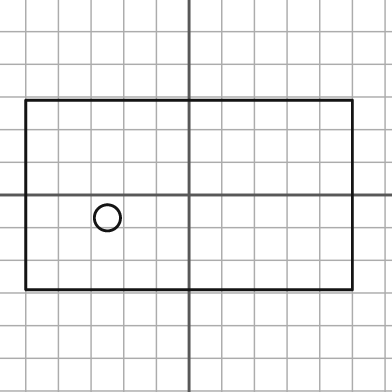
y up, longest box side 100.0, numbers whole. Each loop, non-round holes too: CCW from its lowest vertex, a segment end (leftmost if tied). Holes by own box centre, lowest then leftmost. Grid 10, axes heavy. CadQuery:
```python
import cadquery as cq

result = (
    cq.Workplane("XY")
    .moveTo(-50.0, -29.0)
    .lineTo(50.0, -29.0)
    .lineTo(50.0, 29.0)
    .lineTo(-50.0, 29.0)
    .close()
    .moveTo(-25.0, -7.0)
    .circle(4.0)
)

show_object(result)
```